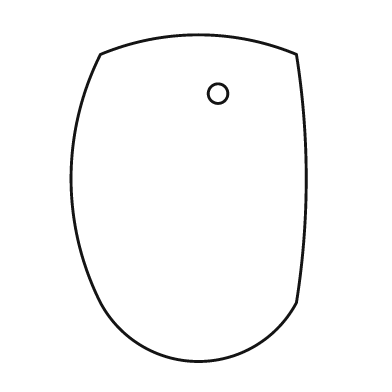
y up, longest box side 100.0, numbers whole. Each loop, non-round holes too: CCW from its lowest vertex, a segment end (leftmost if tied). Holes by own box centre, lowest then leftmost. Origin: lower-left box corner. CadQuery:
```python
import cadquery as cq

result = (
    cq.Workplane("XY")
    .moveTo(9.0, 18.0)
    .threePointArc((39.0, 0.0), (69.0, 18.0))
    .threePointArc((72.0, 56.0), (69.0, 94.0))
    .threePointArc((39.0, 100.0), (9.0, 94.0))
    .threePointArc((0.0, 56.0), (9.0, 18.0))
    .close()
    .moveTo(45.0, 82.0)
    .circle(3.0)
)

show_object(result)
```